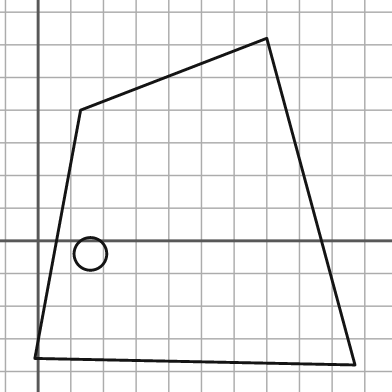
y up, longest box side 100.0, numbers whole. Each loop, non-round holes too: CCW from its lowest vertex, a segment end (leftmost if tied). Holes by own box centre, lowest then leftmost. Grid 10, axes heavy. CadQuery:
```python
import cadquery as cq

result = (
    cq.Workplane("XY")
    .moveTo(97.0, -38.0)
    .lineTo(70.0, 62.0)
    .lineTo(13.0, 40.0)
    .lineTo(-1.0, -36.0)
    .close()
    .moveTo(16.0, -4.0)
    .circle(5.0)
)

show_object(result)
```